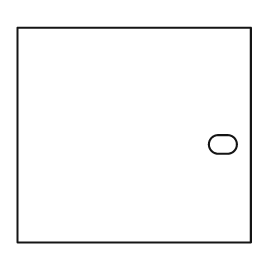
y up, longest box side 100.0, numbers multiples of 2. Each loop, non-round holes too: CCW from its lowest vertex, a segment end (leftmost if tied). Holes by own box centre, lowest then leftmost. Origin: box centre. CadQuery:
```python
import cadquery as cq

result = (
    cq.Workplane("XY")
    .moveTo(-50.0, -46.0)
    .lineTo(50.0, -46.0)
    .lineTo(50.0, 46.0)
    .lineTo(-50.0, 46.0)
    .close()
    .moveTo(36.0, -8.0)
    .lineTo(40.0, -8.0)
    .threePointArc((44.0, -4.0), (40.0, 0.0))
    .lineTo(36.0, 0.0)
    .threePointArc((32.0, -4.0), (36.0, -8.0))
    .close()
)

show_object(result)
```